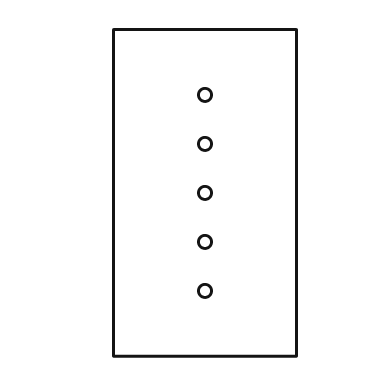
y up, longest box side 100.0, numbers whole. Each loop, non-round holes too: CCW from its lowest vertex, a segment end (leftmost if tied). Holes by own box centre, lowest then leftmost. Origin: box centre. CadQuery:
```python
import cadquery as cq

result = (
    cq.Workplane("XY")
    .moveTo(-28.0, -50.0)
    .lineTo(28.0, -50.0)
    .lineTo(28.0, 50.0)
    .lineTo(-28.0, 50.0)
    .close()
    .moveTo(0.0, -30.0)
    .circle(2.0)
    .moveTo(0.0, -15.0)
    .circle(2.0)
    .moveTo(0.0, 0.0)
    .circle(2.0)
    .moveTo(0.0, 15.0)
    .circle(2.0)
    .moveTo(0.0, 30.0)
    .circle(2.0)
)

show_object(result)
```